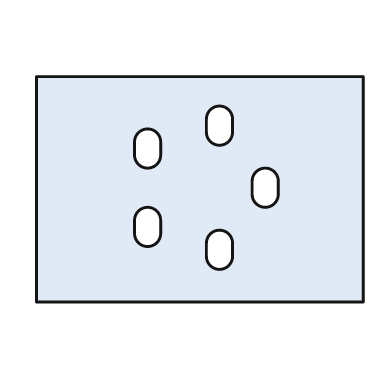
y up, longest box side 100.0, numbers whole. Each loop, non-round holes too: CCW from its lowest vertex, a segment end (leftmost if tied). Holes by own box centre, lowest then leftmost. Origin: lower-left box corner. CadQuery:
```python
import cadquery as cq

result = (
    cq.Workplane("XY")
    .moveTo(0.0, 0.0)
    .lineTo(100.0, 0.0)
    .lineTo(100.0, 69.0)
    .lineTo(0.0, 69.0)
    .close()
    .moveTo(52.0, 14.0)
    .threePointArc((56.0, 10.0), (60.0, 14.0))
    .lineTo(60.0, 18.0)
    .threePointArc((56.0, 22.0), (52.0, 18.0))
    .close()
    .moveTo(30.0, 21.0)
    .threePointArc((34.0, 17.0), (38.0, 21.0))
    .lineTo(38.0, 25.0)
    .threePointArc((34.0, 29.0), (30.0, 25.0))
    .close()
    .moveTo(66.0, 33.0)
    .threePointArc((70.0, 29.0), (74.0, 33.0))
    .lineTo(74.0, 37.0)
    .threePointArc((70.0, 41.0), (66.0, 37.0))
    .close()
    .moveTo(30.0, 45.0)
    .threePointArc((34.0, 41.0), (38.0, 45.0))
    .lineTo(38.0, 49.0)
    .threePointArc((34.0, 53.0), (30.0, 49.0))
    .close()
    .moveTo(52.0, 52.0)
    .threePointArc((56.0, 48.0), (60.0, 52.0))
    .lineTo(60.0, 56.0)
    .threePointArc((56.0, 60.0), (52.0, 56.0))
    .close()
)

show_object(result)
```